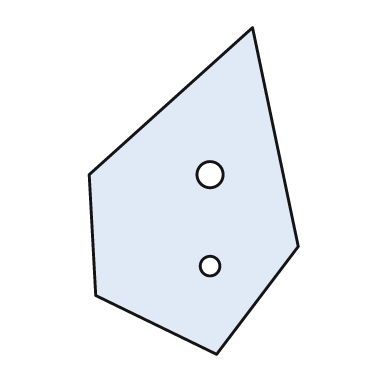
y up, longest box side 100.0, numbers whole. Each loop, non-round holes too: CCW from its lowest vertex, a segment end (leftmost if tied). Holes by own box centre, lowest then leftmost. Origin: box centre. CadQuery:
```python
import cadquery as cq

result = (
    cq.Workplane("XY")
    .moveTo(7.0, -50.0)
    .lineTo(32.0, -17.0)
    .lineTo(18.0, 50.0)
    .lineTo(-32.0, 5.0)
    .lineTo(-30.0, -32.0)
    .close()
    .moveTo(5.0, -23.0)
    .circle(3.0)
    .moveTo(5.0, 5.0)
    .circle(4.0)
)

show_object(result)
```